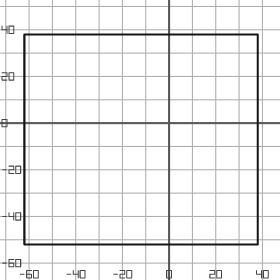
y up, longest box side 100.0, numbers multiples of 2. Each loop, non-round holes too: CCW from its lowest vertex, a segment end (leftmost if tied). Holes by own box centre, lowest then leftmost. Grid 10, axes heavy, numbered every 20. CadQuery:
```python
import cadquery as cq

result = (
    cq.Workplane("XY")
    .moveTo(-62.0, -52.0)
    .lineTo(38.0, -52.0)
    .lineTo(38.0, 38.0)
    .lineTo(-62.0, 38.0)
    .close()
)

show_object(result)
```